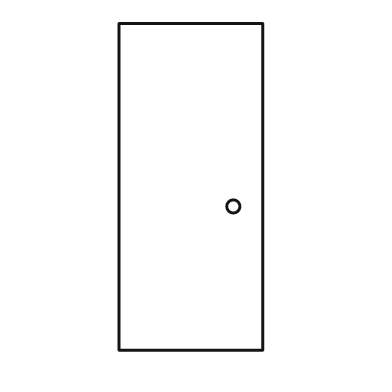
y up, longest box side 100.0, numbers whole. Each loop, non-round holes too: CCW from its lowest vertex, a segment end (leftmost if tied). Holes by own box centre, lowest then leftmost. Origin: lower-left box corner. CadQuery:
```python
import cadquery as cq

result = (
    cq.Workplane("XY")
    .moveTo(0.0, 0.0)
    .lineTo(44.0, 0.0)
    .lineTo(44.0, 100.0)
    .lineTo(0.0, 100.0)
    .close()
    .moveTo(35.0, 44.0)
    .circle(2.0)
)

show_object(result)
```